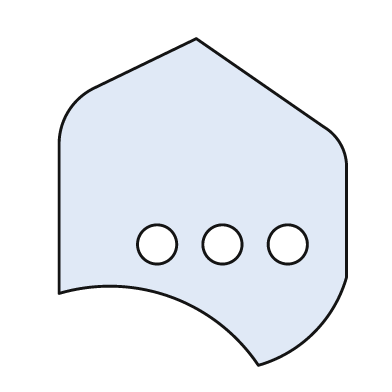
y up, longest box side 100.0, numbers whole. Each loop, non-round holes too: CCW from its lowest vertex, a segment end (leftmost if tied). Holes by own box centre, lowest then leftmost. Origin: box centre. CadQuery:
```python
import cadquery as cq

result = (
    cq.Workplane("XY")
    .moveTo(17.0, -50.0)
    .threePointArc((34.0, -40.0), (44.0, -23.0))
    .lineTo(44.0, 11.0)
    .threePointArc((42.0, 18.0), (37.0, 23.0))
    .lineTo(-2.0, 50.0)
    .lineTo(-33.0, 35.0)
    .threePointArc((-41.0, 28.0), (-44.0, 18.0))
    .lineTo(-44.0, -28.0)
    .threePointArc((-10.0, -29.0), (17.0, -50.0))
    .close()
    .moveTo(-14.0, -13.0)
    .circle(6.0)
    .moveTo(6.0, -13.0)
    .circle(6.0)
    .moveTo(26.0, -13.0)
    .circle(6.0)
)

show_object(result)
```